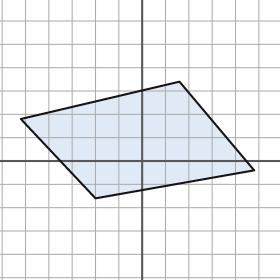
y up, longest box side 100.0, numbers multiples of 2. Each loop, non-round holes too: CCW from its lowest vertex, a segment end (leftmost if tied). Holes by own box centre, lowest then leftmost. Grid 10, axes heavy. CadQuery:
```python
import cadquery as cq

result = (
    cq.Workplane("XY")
    .moveTo(-20.0, -16.0)
    .lineTo(48.0, -4.0)
    .lineTo(16.0, 34.0)
    .lineTo(-52.0, 18.0)
    .close()
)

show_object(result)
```